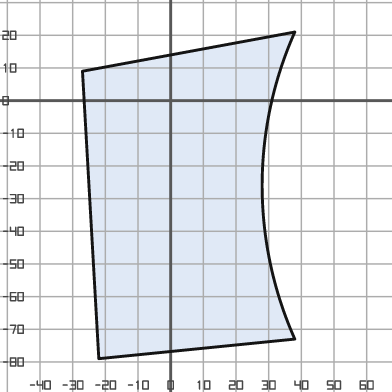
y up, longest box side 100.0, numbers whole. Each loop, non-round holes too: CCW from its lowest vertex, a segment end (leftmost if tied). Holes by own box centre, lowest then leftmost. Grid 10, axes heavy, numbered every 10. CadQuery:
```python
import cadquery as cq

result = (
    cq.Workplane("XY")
    .moveTo(-22.0, -79.0)
    .lineTo(38.0, -73.0)
    .threePointArc((28.0, -26.0), (38.0, 21.0))
    .lineTo(-27.0, 9.0)
    .close()
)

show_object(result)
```